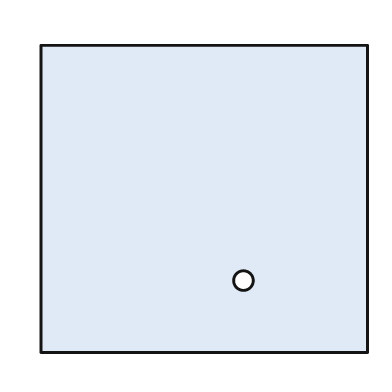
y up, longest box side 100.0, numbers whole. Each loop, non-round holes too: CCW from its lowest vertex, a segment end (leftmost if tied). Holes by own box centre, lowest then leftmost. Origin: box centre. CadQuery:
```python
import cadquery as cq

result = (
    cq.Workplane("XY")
    .moveTo(-50.0, -47.0)
    .lineTo(50.0, -47.0)
    .lineTo(50.0, 47.0)
    .lineTo(-50.0, 47.0)
    .close()
    .moveTo(12.0, -25.0)
    .circle(3.0)
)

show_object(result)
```